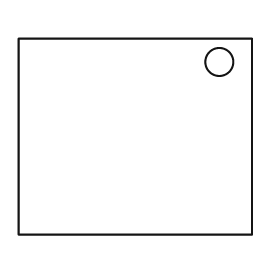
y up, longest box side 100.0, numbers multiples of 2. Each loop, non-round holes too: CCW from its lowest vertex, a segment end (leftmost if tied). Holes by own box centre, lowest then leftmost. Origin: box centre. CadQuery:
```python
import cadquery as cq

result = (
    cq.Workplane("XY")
    .moveTo(-50.0, -42.0)
    .lineTo(50.0, -42.0)
    .lineTo(50.0, 42.0)
    .lineTo(-50.0, 42.0)
    .close()
    .moveTo(36.0, 32.0)
    .circle(6.0)
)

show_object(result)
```